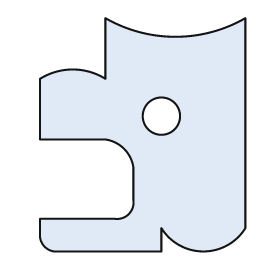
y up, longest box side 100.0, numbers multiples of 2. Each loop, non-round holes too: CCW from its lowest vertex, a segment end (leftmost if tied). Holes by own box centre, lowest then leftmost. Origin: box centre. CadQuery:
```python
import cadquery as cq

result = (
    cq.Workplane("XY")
    .moveTo(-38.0, -50.0)
    .lineTo(8.0, -50.0)
    .lineTo(8.0, -40.0)
    .threePointArc((26.0, -50.0), (44.0, -40.0))
    .lineTo(44.0, 50.0)
    .threePointArc((14.0, 42.0), (-16.0, 50.0))
    .lineTo(-16.0, 24.0)
    .threePointArc((-30.0, 28.0), (-44.0, 24.0))
    .lineTo(-44.0, -2.0)
    .lineTo(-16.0, -2.0)
    .threePointArc((-8.0, -6.0), (-4.0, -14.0))
    .lineTo(-4.0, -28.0)
    .threePointArc((-6.0, -34.0), (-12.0, -36.0))
    .lineTo(-44.0, -36.0)
    .lineTo(-44.0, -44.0)
    .threePointArc((-42.0, -48.0), (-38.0, -50.0))
    .close()
    .moveTo(8.0, 8.0)
    .circle(8.0)
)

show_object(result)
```